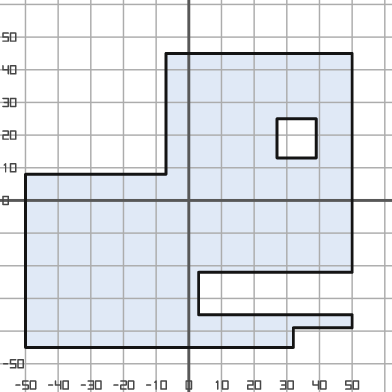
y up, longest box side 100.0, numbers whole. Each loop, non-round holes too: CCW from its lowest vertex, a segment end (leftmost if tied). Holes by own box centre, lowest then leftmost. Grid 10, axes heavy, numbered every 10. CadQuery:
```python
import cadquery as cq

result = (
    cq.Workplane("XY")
    .moveTo(-50.0, -45.0)
    .lineTo(32.0, -45.0)
    .lineTo(32.0, -39.0)
    .lineTo(50.0, -39.0)
    .lineTo(50.0, -35.0)
    .lineTo(3.0, -35.0)
    .lineTo(3.0, -22.0)
    .lineTo(50.0, -22.0)
    .lineTo(50.0, 45.0)
    .lineTo(-7.0, 45.0)
    .lineTo(-7.0, 8.0)
    .lineTo(-50.0, 8.0)
    .close()
    .moveTo(27.0, 13.0)
    .lineTo(39.0, 13.0)
    .lineTo(39.0, 25.0)
    .lineTo(27.0, 25.0)
    .close()
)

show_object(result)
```